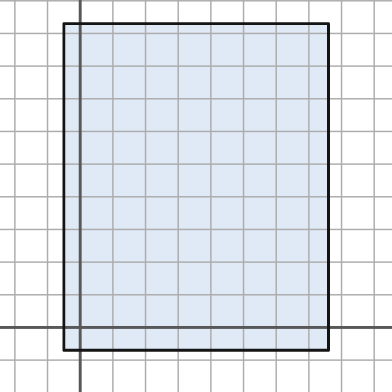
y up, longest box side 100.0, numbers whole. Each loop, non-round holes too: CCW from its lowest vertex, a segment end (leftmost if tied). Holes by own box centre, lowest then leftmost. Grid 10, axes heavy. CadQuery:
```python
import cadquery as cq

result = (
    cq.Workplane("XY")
    .moveTo(-5.0, -7.0)
    .lineTo(76.0, -7.0)
    .lineTo(76.0, 93.0)
    .lineTo(-5.0, 93.0)
    .close()
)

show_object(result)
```